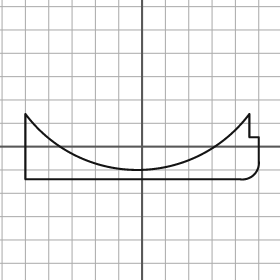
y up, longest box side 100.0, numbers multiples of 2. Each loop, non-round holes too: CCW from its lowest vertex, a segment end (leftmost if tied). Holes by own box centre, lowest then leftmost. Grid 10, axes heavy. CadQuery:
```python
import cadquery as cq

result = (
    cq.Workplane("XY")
    .moveTo(-50.0, -14.0)
    .lineTo(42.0, -14.0)
    .threePointArc((48.0, -12.0), (50.0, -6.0))
    .lineTo(50.0, 4.0)
    .lineTo(46.0, 4.0)
    .lineTo(46.0, 14.0)
    .threePointArc((-2.0, -10.0), (-50.0, 14.0))
    .close()
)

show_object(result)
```